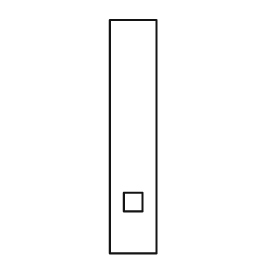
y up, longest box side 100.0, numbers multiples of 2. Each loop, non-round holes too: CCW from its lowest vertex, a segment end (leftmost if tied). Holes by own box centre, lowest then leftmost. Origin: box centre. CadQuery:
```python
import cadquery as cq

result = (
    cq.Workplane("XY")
    .moveTo(-10.0, -50.0)
    .lineTo(10.0, -50.0)
    .lineTo(10.0, 50.0)
    .lineTo(-10.0, 50.0)
    .close()
    .moveTo(-4.0, -32.0)
    .lineTo(4.0, -32.0)
    .lineTo(4.0, -24.0)
    .lineTo(-4.0, -24.0)
    .close()
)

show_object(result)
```